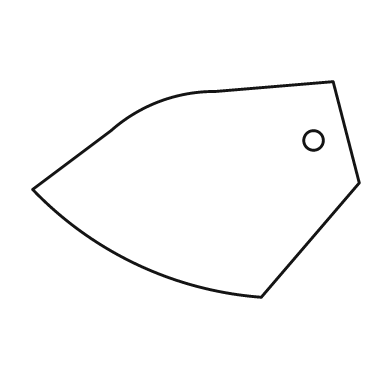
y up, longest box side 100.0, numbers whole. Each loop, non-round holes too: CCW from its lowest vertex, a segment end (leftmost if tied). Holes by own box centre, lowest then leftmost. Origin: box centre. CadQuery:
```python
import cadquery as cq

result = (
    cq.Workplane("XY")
    .moveTo(20.0, -33.0)
    .lineTo(50.0, 2.0)
    .lineTo(42.0, 33.0)
    .lineTo(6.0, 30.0)
    .threePointArc((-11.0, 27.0), (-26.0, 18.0))
    .lineTo(-50.0, 0.0)
    .threePointArc((-18.0, -23.0), (20.0, -33.0))
    .close()
    .moveTo(36.0, 15.0)
    .circle(3.0)
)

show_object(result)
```